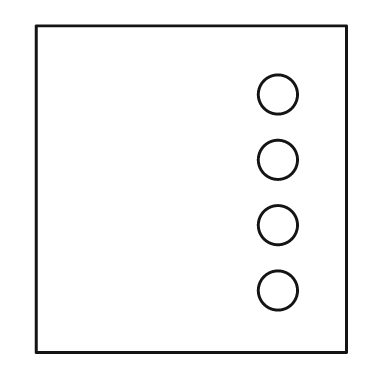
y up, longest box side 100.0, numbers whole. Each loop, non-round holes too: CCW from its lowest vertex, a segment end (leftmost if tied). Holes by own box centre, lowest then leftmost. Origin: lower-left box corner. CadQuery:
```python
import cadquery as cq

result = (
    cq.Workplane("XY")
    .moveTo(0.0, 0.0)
    .lineTo(95.0, 0.0)
    .lineTo(95.0, 100.0)
    .lineTo(0.0, 100.0)
    .close()
    .moveTo(74.0, 19.0)
    .circle(6.0)
    .moveTo(74.0, 39.0)
    .circle(6.0)
    .moveTo(74.0, 59.0)
    .circle(6.0)
    .moveTo(74.0, 79.0)
    .circle(6.0)
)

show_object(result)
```